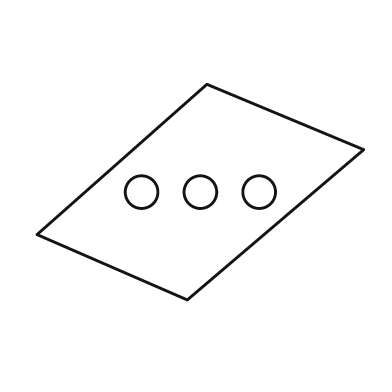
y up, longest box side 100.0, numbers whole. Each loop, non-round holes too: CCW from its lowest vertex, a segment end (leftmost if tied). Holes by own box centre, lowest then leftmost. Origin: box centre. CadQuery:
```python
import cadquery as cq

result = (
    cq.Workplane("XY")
    .moveTo(-4.0, -33.0)
    .lineTo(50.0, 13.0)
    .lineTo(2.0, 33.0)
    .lineTo(-50.0, -13.0)
    .close()
    .moveTo(-18.0, 0.0)
    .circle(5.0)
    .moveTo(0.0, 0.0)
    .circle(5.0)
    .moveTo(18.0, 0.0)
    .circle(5.0)
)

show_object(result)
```